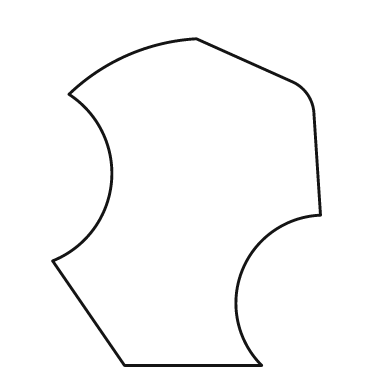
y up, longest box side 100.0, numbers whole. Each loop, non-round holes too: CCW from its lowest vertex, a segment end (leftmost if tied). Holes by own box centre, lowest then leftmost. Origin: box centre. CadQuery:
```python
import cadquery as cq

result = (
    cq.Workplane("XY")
    .moveTo(-19.0, -50.0)
    .lineTo(23.0, -50.0)
    .threePointArc((17.0, -21.0), (41.0, -4.0))
    .lineTo(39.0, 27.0)
    .threePointArc((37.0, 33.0), (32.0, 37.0))
    .lineTo(3.0, 50.0)
    .threePointArc((-18.0, 45.0), (-36.0, 33.0))
    .threePointArc((-23.0, 6.0), (-41.0, -18.0))
    .close()
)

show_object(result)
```